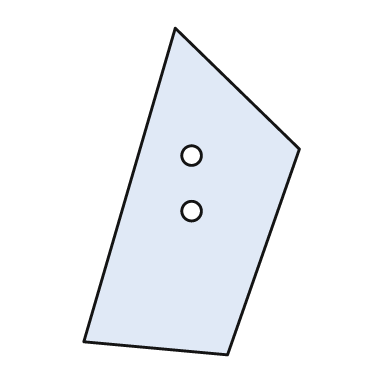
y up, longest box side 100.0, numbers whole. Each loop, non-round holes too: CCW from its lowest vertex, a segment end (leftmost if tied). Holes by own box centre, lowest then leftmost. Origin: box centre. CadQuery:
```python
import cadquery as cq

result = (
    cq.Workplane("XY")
    .moveTo(11.0, -50.0)
    .lineTo(33.0, 13.0)
    .lineTo(-5.0, 50.0)
    .lineTo(-33.0, -46.0)
    .close()
    .moveTo(0.0, -6.0)
    .circle(3.0)
    .moveTo(0.0, 11.0)
    .circle(3.0)
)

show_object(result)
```